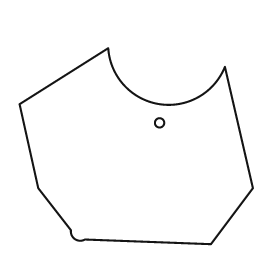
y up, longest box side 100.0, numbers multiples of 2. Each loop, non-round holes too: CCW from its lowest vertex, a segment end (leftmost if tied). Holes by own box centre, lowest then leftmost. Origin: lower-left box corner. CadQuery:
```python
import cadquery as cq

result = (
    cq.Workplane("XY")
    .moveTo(82.0, 0.0)
    .lineTo(100.0, 24.0)
    .lineTo(88.0, 76.0)
    .threePointArc((60.0, 60.0), (38.0, 84.0))
    .lineTo(0.0, 60.0)
    .lineTo(8.0, 24.0)
    .lineTo(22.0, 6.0)
    .threePointArc((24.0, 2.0), (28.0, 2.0))
    .close()
    .moveTo(60.0, 52.0)
    .circle(2.0)
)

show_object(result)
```